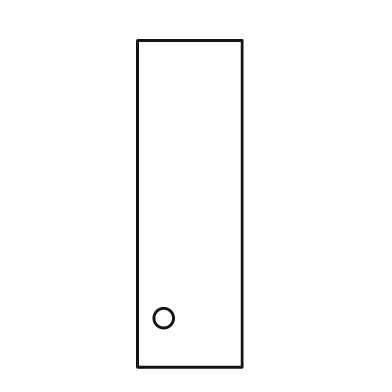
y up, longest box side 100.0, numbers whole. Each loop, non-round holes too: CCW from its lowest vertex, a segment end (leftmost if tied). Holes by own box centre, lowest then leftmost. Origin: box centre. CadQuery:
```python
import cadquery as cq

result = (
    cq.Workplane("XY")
    .moveTo(-16.0, -50.0)
    .lineTo(16.0, -50.0)
    .lineTo(16.0, 50.0)
    .lineTo(-16.0, 50.0)
    .close()
    .moveTo(-8.0, -35.0)
    .circle(3.0)
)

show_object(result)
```